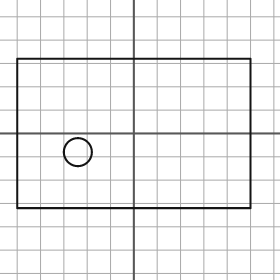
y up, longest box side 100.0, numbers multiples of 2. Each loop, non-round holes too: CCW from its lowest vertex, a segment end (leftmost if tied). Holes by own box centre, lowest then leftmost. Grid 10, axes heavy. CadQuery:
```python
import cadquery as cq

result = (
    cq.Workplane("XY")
    .moveTo(-50.0, -32.0)
    .lineTo(50.0, -32.0)
    .lineTo(50.0, 32.0)
    .lineTo(-50.0, 32.0)
    .close()
    .moveTo(-24.0, -8.0)
    .circle(6.0)
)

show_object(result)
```